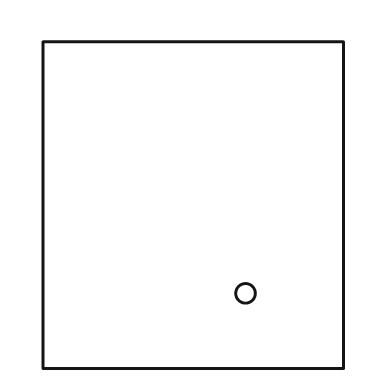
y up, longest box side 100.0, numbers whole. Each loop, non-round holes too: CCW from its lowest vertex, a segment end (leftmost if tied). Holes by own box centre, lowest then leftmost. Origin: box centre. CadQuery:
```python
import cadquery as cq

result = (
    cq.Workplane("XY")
    .moveTo(-46.0, -50.0)
    .lineTo(46.0, -50.0)
    .lineTo(46.0, 50.0)
    .lineTo(-46.0, 50.0)
    .close()
    .moveTo(16.0, -27.0)
    .circle(3.0)
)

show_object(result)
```